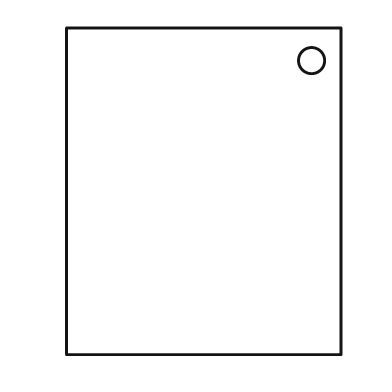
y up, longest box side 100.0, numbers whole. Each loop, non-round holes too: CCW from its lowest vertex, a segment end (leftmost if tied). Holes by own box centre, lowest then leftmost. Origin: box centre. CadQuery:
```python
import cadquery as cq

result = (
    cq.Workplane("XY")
    .moveTo(-42.0, -50.0)
    .lineTo(42.0, -50.0)
    .lineTo(42.0, 50.0)
    .lineTo(-42.0, 50.0)
    .close()
    .moveTo(33.0, 40.0)
    .circle(4.0)
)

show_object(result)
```